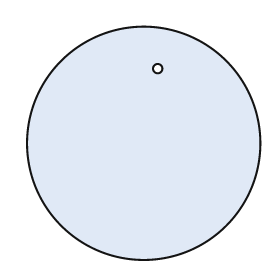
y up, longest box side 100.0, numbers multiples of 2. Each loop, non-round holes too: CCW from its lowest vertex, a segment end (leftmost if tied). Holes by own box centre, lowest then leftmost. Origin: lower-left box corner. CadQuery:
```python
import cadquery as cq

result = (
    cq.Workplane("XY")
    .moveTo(50.0, 50.0)
    .circle(50.0)
    .moveTo(56.0, 82.0)
    .circle(2.0)
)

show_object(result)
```